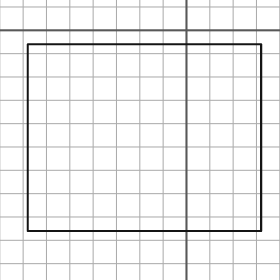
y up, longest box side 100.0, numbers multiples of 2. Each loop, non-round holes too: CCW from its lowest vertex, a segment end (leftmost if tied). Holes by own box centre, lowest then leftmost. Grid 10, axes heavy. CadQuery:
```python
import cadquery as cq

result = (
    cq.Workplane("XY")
    .moveTo(-68.0, -86.0)
    .lineTo(32.0, -86.0)
    .lineTo(32.0, -6.0)
    .lineTo(-68.0, -6.0)
    .close()
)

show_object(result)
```